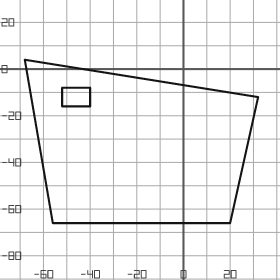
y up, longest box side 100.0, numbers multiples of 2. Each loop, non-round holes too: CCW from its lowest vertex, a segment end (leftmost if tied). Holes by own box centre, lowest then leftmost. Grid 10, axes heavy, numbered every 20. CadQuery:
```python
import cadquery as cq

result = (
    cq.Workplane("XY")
    .moveTo(-56.0, -66.0)
    .lineTo(20.0, -66.0)
    .lineTo(32.0, -12.0)
    .lineTo(-68.0, 4.0)
    .close()
    .moveTo(-52.0, -16.0)
    .lineTo(-40.0, -16.0)
    .lineTo(-40.0, -8.0)
    .lineTo(-52.0, -8.0)
    .close()
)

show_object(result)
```